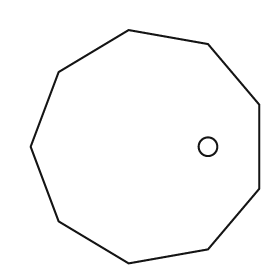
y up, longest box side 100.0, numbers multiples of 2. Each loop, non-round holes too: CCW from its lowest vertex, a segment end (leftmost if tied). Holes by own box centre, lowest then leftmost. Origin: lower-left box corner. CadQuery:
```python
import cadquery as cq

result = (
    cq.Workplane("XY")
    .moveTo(42.0, 0.0)
    .lineTo(76.0, 6.0)
    .lineTo(98.0, 32.0)
    .lineTo(98.0, 68.0)
    .lineTo(76.0, 94.0)
    .lineTo(42.0, 100.0)
    .lineTo(12.0, 82.0)
    .lineTo(0.0, 50.0)
    .lineTo(12.0, 18.0)
    .close()
    .moveTo(76.0, 50.0)
    .circle(4.0)
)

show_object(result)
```